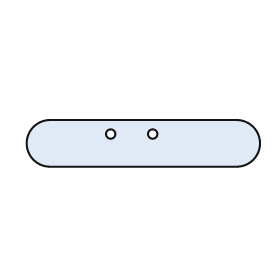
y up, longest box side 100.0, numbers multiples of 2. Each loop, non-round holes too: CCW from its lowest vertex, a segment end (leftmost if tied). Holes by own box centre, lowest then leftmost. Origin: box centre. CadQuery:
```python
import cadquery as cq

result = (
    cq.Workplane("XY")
    .moveTo(-40.0, -10.0)
    .lineTo(40.0, -10.0)
    .threePointArc((50.0, 0.0), (40.0, 10.0))
    .lineTo(-40.0, 10.0)
    .threePointArc((-50.0, 0.0), (-40.0, -10.0))
    .close()
    .moveTo(-14.0, 4.0)
    .circle(2.0)
    .moveTo(4.0, 4.0)
    .circle(2.0)
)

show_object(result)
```